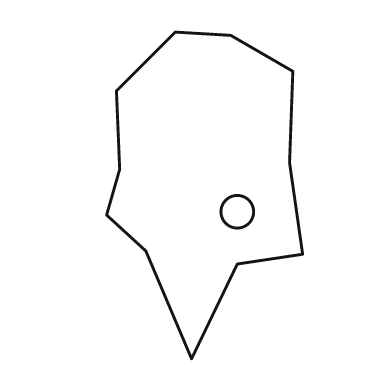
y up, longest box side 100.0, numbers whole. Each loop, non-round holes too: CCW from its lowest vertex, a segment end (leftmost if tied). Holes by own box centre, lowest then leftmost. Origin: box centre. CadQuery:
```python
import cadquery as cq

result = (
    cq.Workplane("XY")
    .moveTo(-4.0, -50.0)
    .lineTo(10.0, -21.0)
    .lineTo(30.0, -18.0)
    .lineTo(26.0, 10.0)
    .lineTo(27.0, 38.0)
    .lineTo(8.0, 49.0)
    .lineTo(-9.0, 50.0)
    .lineTo(-27.0, 32.0)
    .lineTo(-26.0, 8.0)
    .lineTo(-30.0, -6.0)
    .lineTo(-18.0, -17.0)
    .close()
    .moveTo(10.0, -5.0)
    .circle(5.0)
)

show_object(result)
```